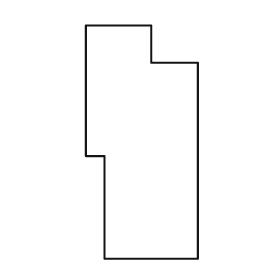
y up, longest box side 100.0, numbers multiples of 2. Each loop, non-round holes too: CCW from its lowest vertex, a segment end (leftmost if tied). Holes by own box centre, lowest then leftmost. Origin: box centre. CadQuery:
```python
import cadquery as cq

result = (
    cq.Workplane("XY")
    .moveTo(-16.0, -50.0)
    .lineTo(24.0, -50.0)
    .lineTo(24.0, 34.0)
    .lineTo(4.0, 34.0)
    .lineTo(4.0, 50.0)
    .lineTo(-24.0, 50.0)
    .lineTo(-24.0, -6.0)
    .lineTo(-16.0, -6.0)
    .close()
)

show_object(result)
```